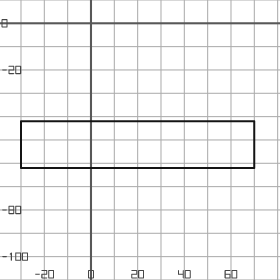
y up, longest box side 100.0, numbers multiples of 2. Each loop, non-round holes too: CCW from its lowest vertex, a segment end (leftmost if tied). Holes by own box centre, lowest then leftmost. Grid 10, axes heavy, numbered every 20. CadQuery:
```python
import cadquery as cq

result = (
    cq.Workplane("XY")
    .moveTo(-30.0, -62.0)
    .lineTo(70.0, -62.0)
    .lineTo(70.0, -42.0)
    .lineTo(-30.0, -42.0)
    .close()
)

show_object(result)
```